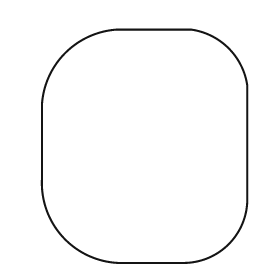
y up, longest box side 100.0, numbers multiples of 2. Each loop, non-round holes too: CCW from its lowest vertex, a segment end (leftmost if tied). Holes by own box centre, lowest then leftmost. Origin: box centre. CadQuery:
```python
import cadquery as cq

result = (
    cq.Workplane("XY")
    .moveTo(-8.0, -50.0)
    .lineTo(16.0, -50.0)
    .threePointArc((36.0, -42.0), (44.0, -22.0))
    .lineTo(44.0, 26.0)
    .threePointArc((36.0, 42.0), (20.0, 50.0))
    .lineTo(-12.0, 50.0)
    .threePointArc((-34.0, 40.0), (-44.0, 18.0))
    .lineTo(-44.0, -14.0)
    .threePointArc((-34.0, -40.0), (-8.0, -50.0))
    .close()
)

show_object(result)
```